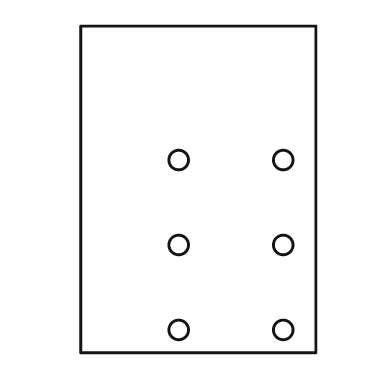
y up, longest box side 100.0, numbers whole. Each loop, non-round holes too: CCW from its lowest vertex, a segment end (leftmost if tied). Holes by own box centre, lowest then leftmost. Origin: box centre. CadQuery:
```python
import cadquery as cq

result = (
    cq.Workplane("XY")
    .moveTo(-36.0, -50.0)
    .lineTo(36.0, -50.0)
    .lineTo(36.0, 50.0)
    .lineTo(-36.0, 50.0)
    .close()
    .moveTo(-6.0, -43.0)
    .circle(3.0)
    .moveTo(26.0, -43.0)
    .circle(3.0)
    .moveTo(-6.0, -17.0)
    .circle(3.0)
    .moveTo(26.0, -17.0)
    .circle(3.0)
    .moveTo(-6.0, 9.0)
    .circle(3.0)
    .moveTo(26.0, 9.0)
    .circle(3.0)
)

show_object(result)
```